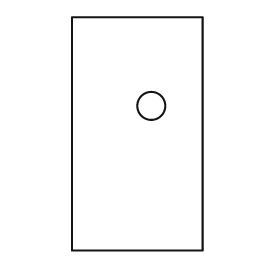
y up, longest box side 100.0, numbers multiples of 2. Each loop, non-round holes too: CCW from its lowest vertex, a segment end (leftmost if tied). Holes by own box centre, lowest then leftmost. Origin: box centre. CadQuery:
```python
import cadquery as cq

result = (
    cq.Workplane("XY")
    .moveTo(-28.0, -50.0)
    .lineTo(28.0, -50.0)
    .lineTo(28.0, 50.0)
    .lineTo(-28.0, 50.0)
    .close()
    .moveTo(6.0, 12.0)
    .circle(6.0)
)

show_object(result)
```